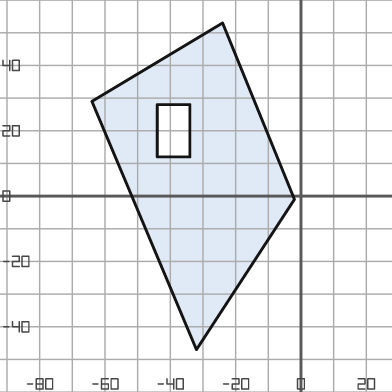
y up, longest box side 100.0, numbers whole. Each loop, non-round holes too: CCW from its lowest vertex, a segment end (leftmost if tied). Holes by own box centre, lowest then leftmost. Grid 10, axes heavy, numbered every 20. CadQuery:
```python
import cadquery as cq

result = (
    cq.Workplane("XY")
    .moveTo(-32.0, -47.0)
    .lineTo(-2.0, -1.0)
    .lineTo(-24.0, 53.0)
    .lineTo(-64.0, 29.0)
    .close()
    .moveTo(-44.0, 12.0)
    .lineTo(-34.0, 12.0)
    .lineTo(-34.0, 28.0)
    .lineTo(-44.0, 28.0)
    .close()
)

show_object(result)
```